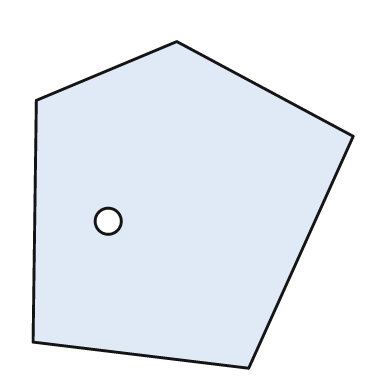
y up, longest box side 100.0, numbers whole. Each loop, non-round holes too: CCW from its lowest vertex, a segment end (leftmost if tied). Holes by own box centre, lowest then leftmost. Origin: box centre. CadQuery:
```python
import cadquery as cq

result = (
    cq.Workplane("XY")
    .moveTo(17.0, -50.0)
    .lineTo(49.0, 21.0)
    .lineTo(-5.0, 50.0)
    .lineTo(-48.0, 32.0)
    .lineTo(-49.0, -42.0)
    .close()
    .moveTo(-26.0, -5.0)
    .circle(4.0)
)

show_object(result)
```